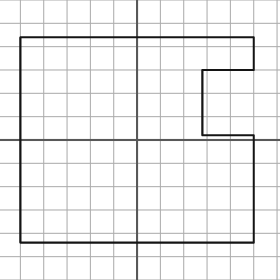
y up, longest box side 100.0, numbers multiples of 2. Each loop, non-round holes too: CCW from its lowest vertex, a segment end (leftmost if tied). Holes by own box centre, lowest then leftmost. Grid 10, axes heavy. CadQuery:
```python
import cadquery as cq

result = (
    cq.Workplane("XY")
    .moveTo(-50.0, -44.0)
    .lineTo(50.0, -44.0)
    .lineTo(50.0, 2.0)
    .lineTo(28.0, 2.0)
    .lineTo(28.0, 30.0)
    .lineTo(50.0, 30.0)
    .lineTo(50.0, 44.0)
    .lineTo(-50.0, 44.0)
    .close()
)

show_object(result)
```